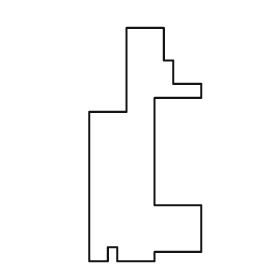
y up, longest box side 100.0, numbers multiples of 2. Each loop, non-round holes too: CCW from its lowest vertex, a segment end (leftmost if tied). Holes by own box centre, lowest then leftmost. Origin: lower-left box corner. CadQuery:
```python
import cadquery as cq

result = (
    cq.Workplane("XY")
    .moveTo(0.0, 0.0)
    .lineTo(8.0, 0.0)
    .lineTo(8.0, 6.0)
    .lineTo(12.0, 6.0)
    .lineTo(12.0, 0.0)
    .lineTo(28.0, 0.0)
    .lineTo(28.0, 4.0)
    .lineTo(48.0, 4.0)
    .lineTo(48.0, 24.0)
    .lineTo(28.0, 24.0)
    .lineTo(28.0, 70.0)
    .lineTo(48.0, 70.0)
    .lineTo(48.0, 76.0)
    .lineTo(36.0, 76.0)
    .lineTo(36.0, 86.0)
    .lineTo(32.0, 86.0)
    .lineTo(32.0, 100.0)
    .lineTo(16.0, 100.0)
    .lineTo(16.0, 64.0)
    .lineTo(0.0, 64.0)
    .close()
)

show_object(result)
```